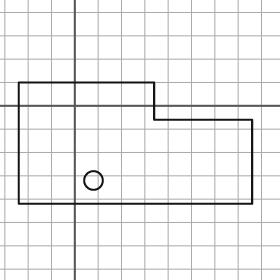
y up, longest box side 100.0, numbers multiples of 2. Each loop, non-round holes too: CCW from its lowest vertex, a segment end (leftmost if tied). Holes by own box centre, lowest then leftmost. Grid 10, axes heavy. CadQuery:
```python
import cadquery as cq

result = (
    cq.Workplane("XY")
    .moveTo(-24.0, -42.0)
    .lineTo(76.0, -42.0)
    .lineTo(76.0, -6.0)
    .lineTo(34.0, -6.0)
    .lineTo(34.0, 10.0)
    .lineTo(-24.0, 10.0)
    .close()
    .moveTo(8.0, -32.0)
    .circle(4.0)
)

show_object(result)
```